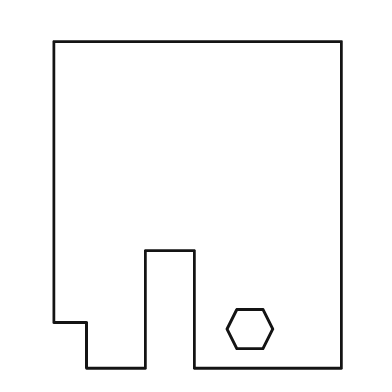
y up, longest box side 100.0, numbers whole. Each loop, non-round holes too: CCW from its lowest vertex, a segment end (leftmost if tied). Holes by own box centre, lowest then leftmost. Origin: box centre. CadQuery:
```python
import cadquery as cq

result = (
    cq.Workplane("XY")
    .moveTo(-34.0, -50.0)
    .lineTo(-16.0, -50.0)
    .lineTo(-16.0, -14.0)
    .lineTo(-1.0, -14.0)
    .lineTo(-1.0, -50.0)
    .lineTo(44.0, -50.0)
    .lineTo(44.0, 50.0)
    .lineTo(-44.0, 50.0)
    .lineTo(-44.0, -36.0)
    .lineTo(-34.0, -36.0)
    .close()
    .moveTo(12.0, -44.0)
    .lineTo(20.0, -44.0)
    .lineTo(23.0, -38.0)
    .lineTo(20.0, -32.0)
    .lineTo(12.0, -32.0)
    .lineTo(9.0, -38.0)
    .close()
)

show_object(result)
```